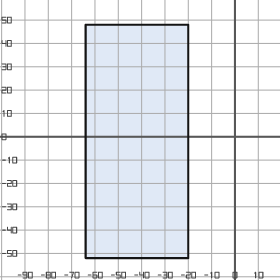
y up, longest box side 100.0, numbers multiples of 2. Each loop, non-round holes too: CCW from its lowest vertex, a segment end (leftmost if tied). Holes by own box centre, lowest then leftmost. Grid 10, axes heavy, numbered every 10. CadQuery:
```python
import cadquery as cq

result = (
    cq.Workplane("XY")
    .moveTo(-64.0, -52.0)
    .lineTo(-20.0, -52.0)
    .lineTo(-20.0, 48.0)
    .lineTo(-64.0, 48.0)
    .close()
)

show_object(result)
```